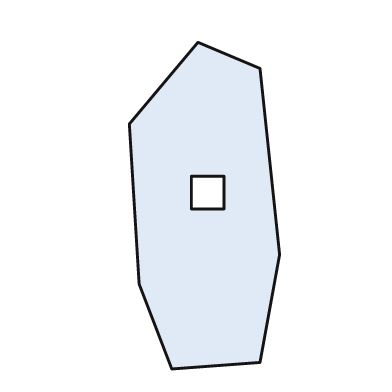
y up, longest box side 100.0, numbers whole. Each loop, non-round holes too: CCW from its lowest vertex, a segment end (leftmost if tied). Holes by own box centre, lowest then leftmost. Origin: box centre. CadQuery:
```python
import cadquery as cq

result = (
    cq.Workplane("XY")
    .moveTo(-10.0, -50.0)
    .lineTo(17.0, -48.0)
    .lineTo(23.0, -15.0)
    .lineTo(17.0, 42.0)
    .lineTo(-2.0, 50.0)
    .lineTo(-23.0, 25.0)
    .lineTo(-20.0, -24.0)
    .close()
    .moveTo(-4.0, -1.0)
    .lineTo(6.0, -1.0)
    .lineTo(6.0, 9.0)
    .lineTo(-4.0, 9.0)
    .close()
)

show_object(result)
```